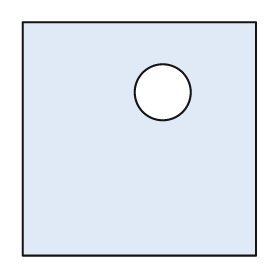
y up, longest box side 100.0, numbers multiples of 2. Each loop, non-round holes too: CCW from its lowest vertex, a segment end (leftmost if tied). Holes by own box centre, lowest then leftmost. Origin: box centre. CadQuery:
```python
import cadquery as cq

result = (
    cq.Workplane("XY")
    .moveTo(-50.0, -50.0)
    .lineTo(50.0, -50.0)
    .lineTo(50.0, 50.0)
    .lineTo(-50.0, 50.0)
    .close()
    .moveTo(10.0, 20.0)
    .circle(12.0)
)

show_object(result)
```